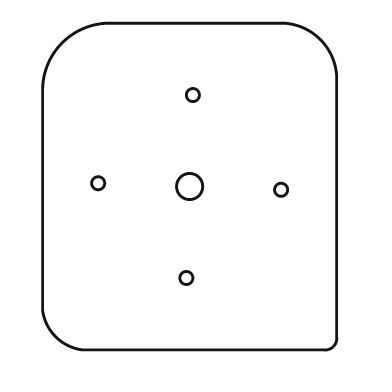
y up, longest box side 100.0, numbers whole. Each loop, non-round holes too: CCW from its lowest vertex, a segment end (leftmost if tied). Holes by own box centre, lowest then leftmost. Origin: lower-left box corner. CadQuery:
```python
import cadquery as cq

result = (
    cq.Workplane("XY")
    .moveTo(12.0, 0.0)
    .lineTo(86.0, 0.0)
    .threePointArc((89.0, 1.0), (90.0, 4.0))
    .lineTo(90.0, 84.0)
    .threePointArc((85.0, 95.0), (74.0, 100.0))
    .lineTo(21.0, 100.0)
    .threePointArc((6.0, 94.0), (0.0, 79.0))
    .lineTo(0.0, 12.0)
    .threePointArc((4.0, 4.0), (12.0, 0.0))
    .close()
    .moveTo(44.0, 22.0)
    .circle(2.0)
    .moveTo(73.0, 49.0)
    .circle(2.0)
    .moveTo(45.0, 50.0)
    .circle(4.0)
    .moveTo(17.0, 51.0)
    .circle(2.0)
    .moveTo(46.0, 78.0)
    .circle(2.0)
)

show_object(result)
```